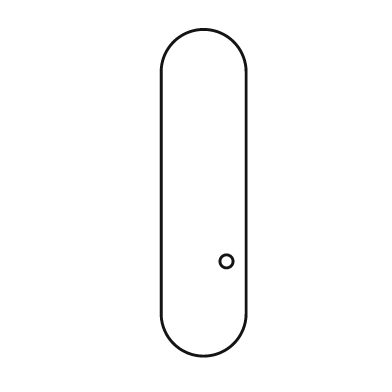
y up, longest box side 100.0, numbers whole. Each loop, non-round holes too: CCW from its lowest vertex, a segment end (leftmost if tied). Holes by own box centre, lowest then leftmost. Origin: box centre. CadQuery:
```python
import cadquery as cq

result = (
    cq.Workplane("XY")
    .moveTo(-13.0, -37.0)
    .threePointArc((0.0, -50.0), (13.0, -37.0))
    .lineTo(13.0, 37.0)
    .threePointArc((0.0, 50.0), (-13.0, 37.0))
    .close()
    .moveTo(7.0, -21.0)
    .circle(2.0)
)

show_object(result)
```